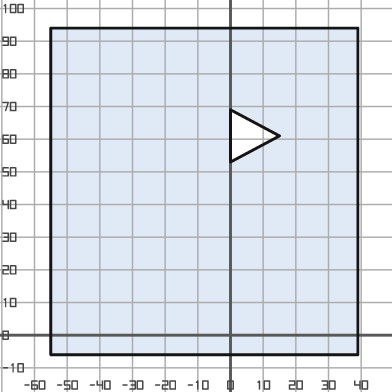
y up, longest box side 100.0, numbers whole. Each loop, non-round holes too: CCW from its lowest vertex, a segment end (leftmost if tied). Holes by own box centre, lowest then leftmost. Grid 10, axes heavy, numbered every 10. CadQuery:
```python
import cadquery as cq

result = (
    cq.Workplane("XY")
    .moveTo(-55.0, -6.0)
    .lineTo(39.0, -6.0)
    .lineTo(39.0, 94.0)
    .lineTo(-55.0, 94.0)
    .close()
    .moveTo(0.0, 53.0)
    .lineTo(15.0, 61.0)
    .lineTo(0.0, 69.0)
    .close()
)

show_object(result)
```